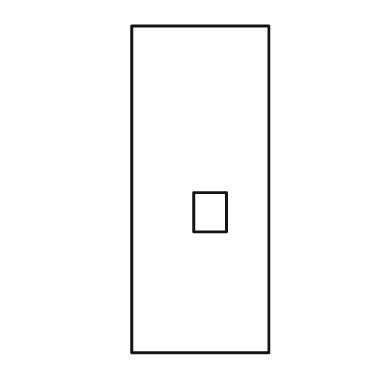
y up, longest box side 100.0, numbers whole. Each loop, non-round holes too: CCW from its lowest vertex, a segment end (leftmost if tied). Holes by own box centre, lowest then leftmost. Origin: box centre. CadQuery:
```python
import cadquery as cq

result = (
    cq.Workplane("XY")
    .moveTo(-21.0, -50.0)
    .lineTo(21.0, -50.0)
    .lineTo(21.0, 50.0)
    .lineTo(-21.0, 50.0)
    .close()
    .moveTo(-2.0, -13.0)
    .lineTo(8.0, -13.0)
    .lineTo(8.0, -1.0)
    .lineTo(-2.0, -1.0)
    .close()
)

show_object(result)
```